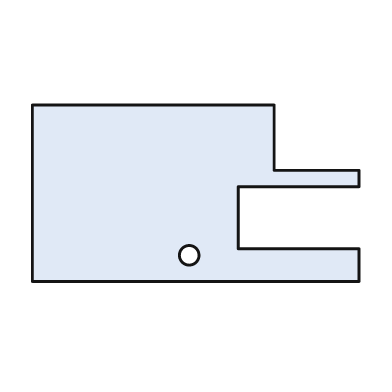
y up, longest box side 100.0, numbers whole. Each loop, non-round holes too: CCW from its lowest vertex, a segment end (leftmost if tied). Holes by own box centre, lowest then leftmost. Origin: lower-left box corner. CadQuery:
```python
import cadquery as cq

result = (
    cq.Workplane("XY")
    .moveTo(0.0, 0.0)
    .lineTo(100.0, 0.0)
    .lineTo(100.0, 10.0)
    .lineTo(63.0, 10.0)
    .lineTo(63.0, 29.0)
    .lineTo(100.0, 29.0)
    .lineTo(100.0, 34.0)
    .lineTo(74.0, 34.0)
    .lineTo(74.0, 54.0)
    .lineTo(0.0, 54.0)
    .close()
    .moveTo(48.0, 8.0)
    .circle(3.0)
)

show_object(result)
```